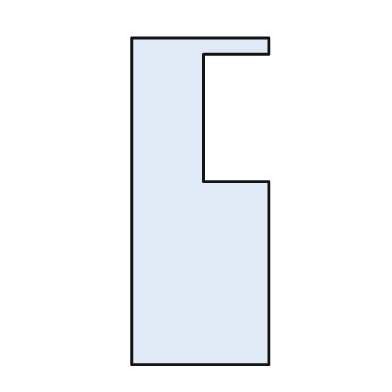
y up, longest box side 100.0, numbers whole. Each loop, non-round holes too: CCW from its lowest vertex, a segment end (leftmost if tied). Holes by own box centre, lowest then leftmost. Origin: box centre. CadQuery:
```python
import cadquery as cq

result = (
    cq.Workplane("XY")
    .moveTo(-21.0, -50.0)
    .lineTo(21.0, -50.0)
    .lineTo(21.0, 6.0)
    .lineTo(1.0, 6.0)
    .lineTo(1.0, 45.0)
    .lineTo(21.0, 45.0)
    .lineTo(21.0, 50.0)
    .lineTo(-21.0, 50.0)
    .close()
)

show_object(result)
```